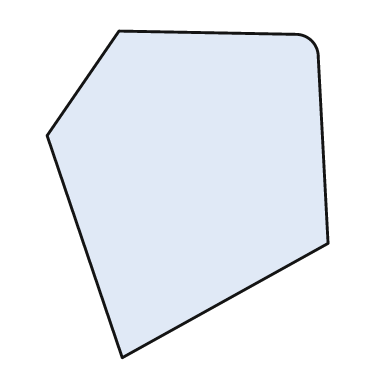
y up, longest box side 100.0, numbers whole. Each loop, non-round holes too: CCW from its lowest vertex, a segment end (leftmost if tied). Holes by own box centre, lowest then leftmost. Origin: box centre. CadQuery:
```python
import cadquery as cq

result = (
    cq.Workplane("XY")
    .moveTo(-20.0, -50.0)
    .lineTo(43.0, -15.0)
    .lineTo(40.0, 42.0)
    .threePointArc((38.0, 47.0), (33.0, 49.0))
    .lineTo(-21.0, 50.0)
    .lineTo(-43.0, 18.0)
    .close()
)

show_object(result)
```